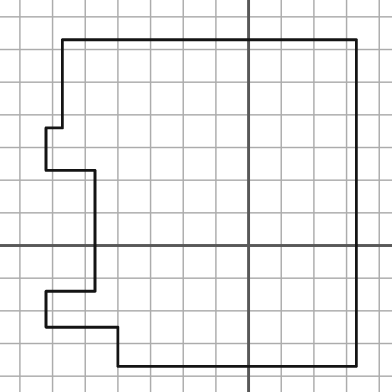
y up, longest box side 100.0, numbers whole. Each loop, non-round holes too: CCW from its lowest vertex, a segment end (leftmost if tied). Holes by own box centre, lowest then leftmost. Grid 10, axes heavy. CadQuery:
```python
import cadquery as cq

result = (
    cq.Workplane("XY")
    .moveTo(-40.0, -37.0)
    .lineTo(33.0, -37.0)
    .lineTo(33.0, 63.0)
    .lineTo(-57.0, 63.0)
    .lineTo(-57.0, 36.0)
    .lineTo(-62.0, 36.0)
    .lineTo(-62.0, 23.0)
    .lineTo(-47.0, 23.0)
    .lineTo(-47.0, -14.0)
    .lineTo(-62.0, -14.0)
    .lineTo(-62.0, -25.0)
    .lineTo(-40.0, -25.0)
    .close()
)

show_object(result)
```